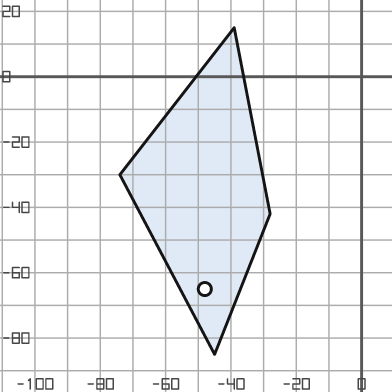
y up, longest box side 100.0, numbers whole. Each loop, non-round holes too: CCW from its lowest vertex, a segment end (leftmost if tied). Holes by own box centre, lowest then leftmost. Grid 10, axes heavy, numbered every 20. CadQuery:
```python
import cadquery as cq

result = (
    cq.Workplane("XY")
    .moveTo(-45.0, -85.0)
    .lineTo(-28.0, -42.0)
    .lineTo(-39.0, 15.0)
    .lineTo(-74.0, -30.0)
    .close()
    .moveTo(-48.0, -65.0)
    .circle(2.0)
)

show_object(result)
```